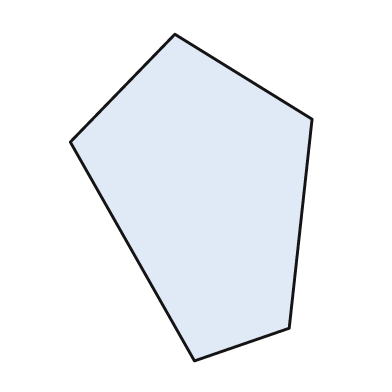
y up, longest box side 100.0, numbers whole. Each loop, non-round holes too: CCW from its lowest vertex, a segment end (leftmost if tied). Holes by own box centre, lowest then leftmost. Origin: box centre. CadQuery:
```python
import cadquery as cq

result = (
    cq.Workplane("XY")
    .moveTo(1.0, -50.0)
    .lineTo(30.0, -40.0)
    .lineTo(37.0, 24.0)
    .lineTo(-5.0, 50.0)
    .lineTo(-37.0, 17.0)
    .close()
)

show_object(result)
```